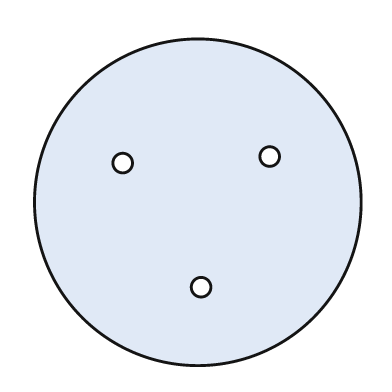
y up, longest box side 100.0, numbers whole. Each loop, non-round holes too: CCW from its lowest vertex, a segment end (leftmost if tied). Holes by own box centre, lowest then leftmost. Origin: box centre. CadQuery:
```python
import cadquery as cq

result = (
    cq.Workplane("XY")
    .moveTo(0.0, 0.0)
    .circle(50.0)
    .moveTo(1.0, -26.0)
    .circle(3.0)
    .moveTo(-23.0, 12.0)
    .circle(3.0)
    .moveTo(22.0, 14.0)
    .circle(3.0)
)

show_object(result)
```